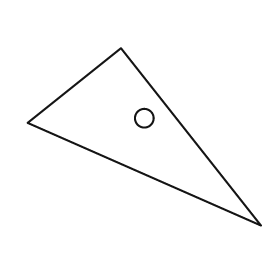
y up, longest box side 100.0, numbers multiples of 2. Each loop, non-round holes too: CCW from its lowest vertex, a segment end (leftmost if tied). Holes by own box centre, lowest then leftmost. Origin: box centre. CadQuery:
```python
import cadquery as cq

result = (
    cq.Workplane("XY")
    .moveTo(50.0, -38.0)
    .lineTo(-10.0, 38.0)
    .lineTo(-50.0, 6.0)
    .close()
    .moveTo(0.0, 8.0)
    .circle(4.0)
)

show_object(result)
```